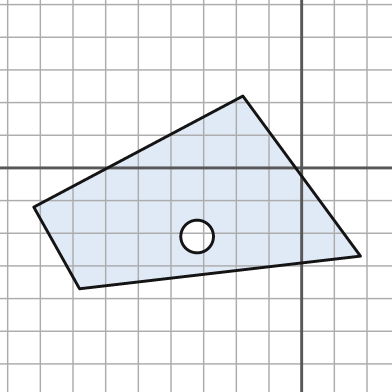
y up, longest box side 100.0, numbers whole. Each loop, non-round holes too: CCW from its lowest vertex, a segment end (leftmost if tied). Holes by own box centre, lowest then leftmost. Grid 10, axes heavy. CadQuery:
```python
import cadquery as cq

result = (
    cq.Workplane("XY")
    .moveTo(-68.0, -37.0)
    .lineTo(18.0, -27.0)
    .lineTo(-18.0, 22.0)
    .lineTo(-82.0, -12.0)
    .close()
    .moveTo(-32.0, -21.0)
    .circle(5.0)
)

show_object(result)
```